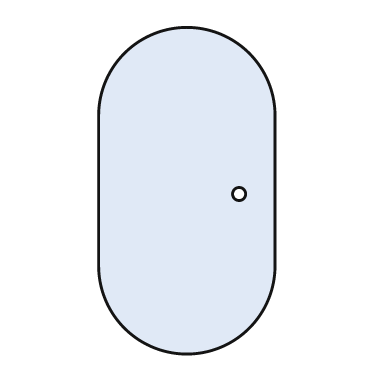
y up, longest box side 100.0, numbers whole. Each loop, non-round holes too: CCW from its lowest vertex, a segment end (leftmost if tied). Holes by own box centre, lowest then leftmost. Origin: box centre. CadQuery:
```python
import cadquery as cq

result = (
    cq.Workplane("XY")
    .moveTo(-27.0, -23.0)
    .threePointArc((0.0, -50.0), (27.0, -23.0))
    .lineTo(27.0, 23.0)
    .threePointArc((0.0, 50.0), (-27.0, 23.0))
    .close()
    .moveTo(16.0, -1.0)
    .circle(2.0)
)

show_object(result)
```